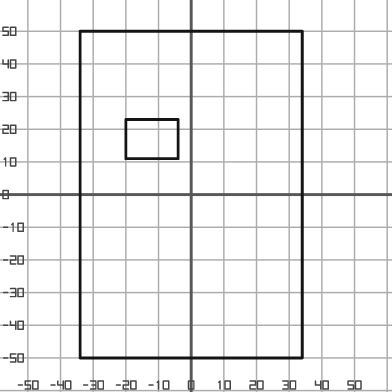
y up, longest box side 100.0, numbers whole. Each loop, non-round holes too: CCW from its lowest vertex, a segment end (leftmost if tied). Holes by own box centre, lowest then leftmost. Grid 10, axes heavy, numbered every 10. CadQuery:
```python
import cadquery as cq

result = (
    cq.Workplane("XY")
    .moveTo(-34.0, -50.0)
    .lineTo(34.0, -50.0)
    .lineTo(34.0, 50.0)
    .lineTo(-34.0, 50.0)
    .close()
    .moveTo(-20.0, 11.0)
    .lineTo(-4.0, 11.0)
    .lineTo(-4.0, 23.0)
    .lineTo(-20.0, 23.0)
    .close()
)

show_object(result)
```